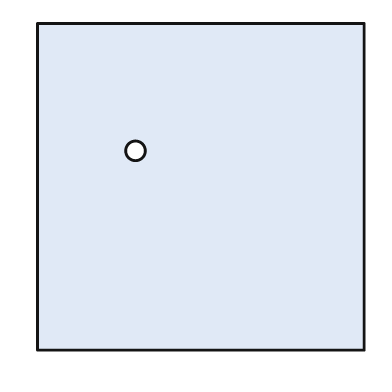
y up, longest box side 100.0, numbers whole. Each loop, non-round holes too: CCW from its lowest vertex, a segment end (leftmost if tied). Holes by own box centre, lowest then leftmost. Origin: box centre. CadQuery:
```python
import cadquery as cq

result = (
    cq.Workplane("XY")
    .moveTo(-50.0, -50.0)
    .lineTo(50.0, -50.0)
    .lineTo(50.0, 50.0)
    .lineTo(-50.0, 50.0)
    .close()
    .moveTo(-20.0, 11.0)
    .circle(3.0)
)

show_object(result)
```